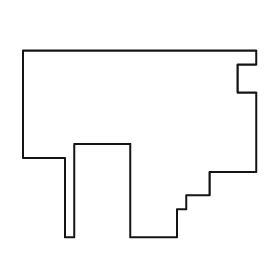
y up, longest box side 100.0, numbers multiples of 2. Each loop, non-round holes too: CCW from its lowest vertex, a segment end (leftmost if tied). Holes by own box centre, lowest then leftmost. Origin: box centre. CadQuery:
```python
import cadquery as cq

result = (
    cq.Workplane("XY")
    .moveTo(-32.0, -40.0)
    .lineTo(-28.0, -40.0)
    .lineTo(-28.0, 0.0)
    .lineTo(-4.0, 0.0)
    .lineTo(-4.0, -40.0)
    .lineTo(16.0, -40.0)
    .lineTo(16.0, -28.0)
    .lineTo(20.0, -28.0)
    .lineTo(20.0, -22.0)
    .lineTo(30.0, -22.0)
    .lineTo(30.0, -12.0)
    .lineTo(50.0, -12.0)
    .lineTo(50.0, 22.0)
    .lineTo(42.0, 22.0)
    .lineTo(42.0, 34.0)
    .lineTo(50.0, 34.0)
    .lineTo(50.0, 40.0)
    .lineTo(-50.0, 40.0)
    .lineTo(-50.0, -6.0)
    .lineTo(-32.0, -6.0)
    .close()
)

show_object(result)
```